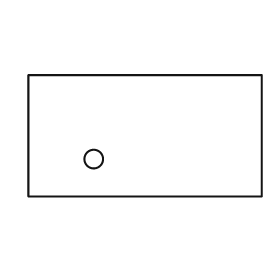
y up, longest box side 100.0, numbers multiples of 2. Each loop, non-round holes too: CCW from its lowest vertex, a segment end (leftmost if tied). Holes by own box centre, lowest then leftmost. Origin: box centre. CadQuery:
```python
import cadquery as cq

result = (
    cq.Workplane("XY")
    .moveTo(-50.0, -26.0)
    .lineTo(50.0, -26.0)
    .lineTo(50.0, 26.0)
    .lineTo(-50.0, 26.0)
    .close()
    .moveTo(-22.0, -10.0)
    .circle(4.0)
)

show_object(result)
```